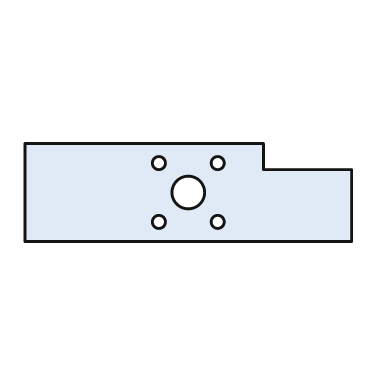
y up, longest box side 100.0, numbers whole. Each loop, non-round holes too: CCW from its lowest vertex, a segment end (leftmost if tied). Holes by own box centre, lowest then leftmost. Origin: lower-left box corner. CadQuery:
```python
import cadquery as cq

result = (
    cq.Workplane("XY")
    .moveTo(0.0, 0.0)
    .lineTo(100.0, 0.0)
    .lineTo(100.0, 22.0)
    .lineTo(73.0, 22.0)
    .lineTo(73.0, 30.0)
    .lineTo(0.0, 30.0)
    .close()
    .moveTo(41.0, 6.0)
    .circle(2.0)
    .moveTo(59.0, 6.0)
    .circle(2.0)
    .moveTo(50.0, 15.0)
    .circle(5.0)
    .moveTo(41.0, 24.0)
    .circle(2.0)
    .moveTo(59.0, 24.0)
    .circle(2.0)
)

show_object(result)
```